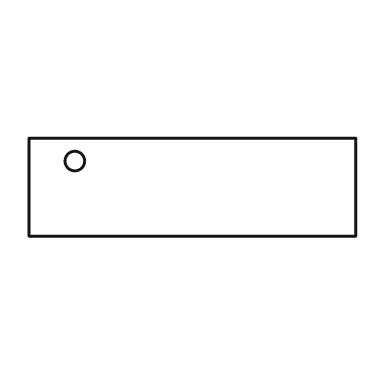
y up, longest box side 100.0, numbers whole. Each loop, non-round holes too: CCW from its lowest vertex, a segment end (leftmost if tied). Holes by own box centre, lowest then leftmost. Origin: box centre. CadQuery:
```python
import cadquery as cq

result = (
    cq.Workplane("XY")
    .moveTo(-50.0, -15.0)
    .lineTo(50.0, -15.0)
    .lineTo(50.0, 15.0)
    .lineTo(-50.0, 15.0)
    .close()
    .moveTo(-36.0, 8.0)
    .circle(3.0)
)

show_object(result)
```